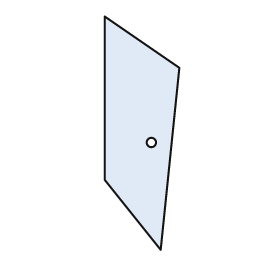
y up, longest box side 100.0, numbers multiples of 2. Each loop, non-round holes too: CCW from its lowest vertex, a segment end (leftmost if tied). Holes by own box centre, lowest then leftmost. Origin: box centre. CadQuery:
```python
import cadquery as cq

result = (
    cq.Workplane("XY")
    .moveTo(8.0, -50.0)
    .lineTo(16.0, 28.0)
    .lineTo(-16.0, 50.0)
    .lineTo(-16.0, -20.0)
    .close()
    .moveTo(4.0, -4.0)
    .circle(2.0)
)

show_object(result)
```